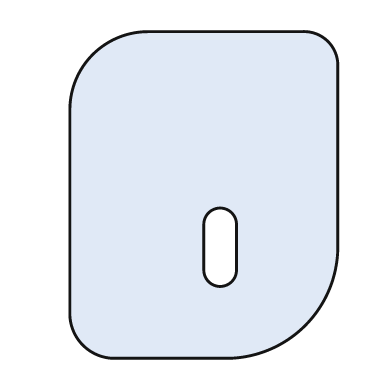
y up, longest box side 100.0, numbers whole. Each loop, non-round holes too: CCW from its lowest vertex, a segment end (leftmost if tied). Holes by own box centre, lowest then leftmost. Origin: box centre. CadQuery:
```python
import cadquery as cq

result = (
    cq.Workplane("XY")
    .moveTo(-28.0, -50.0)
    .lineTo(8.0, -50.0)
    .threePointArc((31.0, -40.0), (41.0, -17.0))
    .lineTo(41.0, 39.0)
    .threePointArc((38.0, 47.0), (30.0, 50.0))
    .lineTo(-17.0, 50.0)
    .threePointArc((-34.0, 43.0), (-41.0, 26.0))
    .lineTo(-41.0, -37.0)
    .threePointArc((-37.0, -46.0), (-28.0, -50.0))
    .close()
    .moveTo(0.0, -23.0)
    .threePointArc((5.0, -28.0), (10.0, -23.0))
    .lineTo(10.0, -9.0)
    .threePointArc((5.0, -4.0), (0.0, -9.0))
    .close()
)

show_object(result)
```